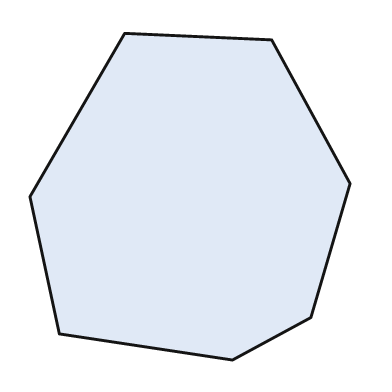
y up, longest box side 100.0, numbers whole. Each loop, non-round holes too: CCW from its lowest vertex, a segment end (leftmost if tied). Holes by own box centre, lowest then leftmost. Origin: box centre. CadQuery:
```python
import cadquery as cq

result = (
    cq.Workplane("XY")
    .moveTo(13.0, -50.0)
    .lineTo(37.0, -37.0)
    .lineTo(49.0, 4.0)
    .lineTo(25.0, 48.0)
    .lineTo(-20.0, 50.0)
    .lineTo(-49.0, 0.0)
    .lineTo(-40.0, -42.0)
    .close()
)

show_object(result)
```